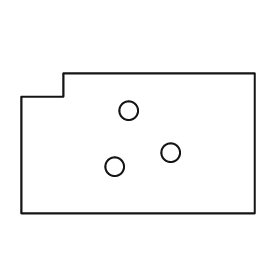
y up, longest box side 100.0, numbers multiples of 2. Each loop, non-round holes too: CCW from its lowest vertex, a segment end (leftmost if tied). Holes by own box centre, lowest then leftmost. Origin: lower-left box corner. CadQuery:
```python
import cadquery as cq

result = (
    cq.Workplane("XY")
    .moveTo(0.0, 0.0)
    .lineTo(100.0, 0.0)
    .lineTo(100.0, 60.0)
    .lineTo(18.0, 60.0)
    .lineTo(18.0, 50.0)
    .lineTo(0.0, 50.0)
    .close()
    .moveTo(40.0, 20.0)
    .circle(4.0)
    .moveTo(64.0, 26.0)
    .circle(4.0)
    .moveTo(46.0, 44.0)
    .circle(4.0)
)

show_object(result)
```